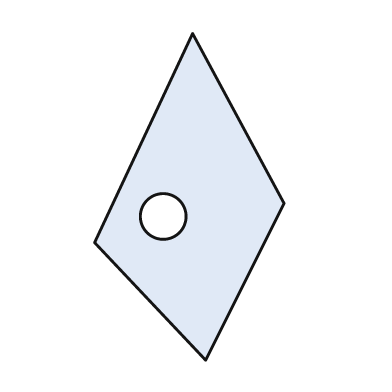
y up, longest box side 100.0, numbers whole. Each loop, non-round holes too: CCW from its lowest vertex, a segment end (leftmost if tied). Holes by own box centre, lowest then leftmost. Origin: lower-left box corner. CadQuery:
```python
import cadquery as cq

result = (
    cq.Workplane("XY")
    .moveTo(34.0, 0.0)
    .lineTo(58.0, 48.0)
    .lineTo(30.0, 100.0)
    .lineTo(0.0, 36.0)
    .close()
    .moveTo(21.0, 44.0)
    .circle(7.0)
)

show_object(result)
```